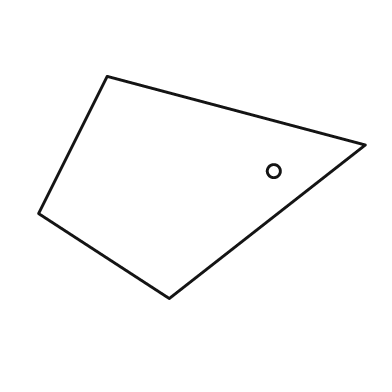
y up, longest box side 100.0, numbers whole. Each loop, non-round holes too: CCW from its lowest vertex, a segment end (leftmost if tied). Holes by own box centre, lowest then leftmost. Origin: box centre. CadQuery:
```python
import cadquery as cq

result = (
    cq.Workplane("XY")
    .moveTo(-10.0, -34.0)
    .lineTo(50.0, 13.0)
    .lineTo(-29.0, 34.0)
    .lineTo(-50.0, -8.0)
    .close()
    .moveTo(22.0, 5.0)
    .circle(2.0)
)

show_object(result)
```